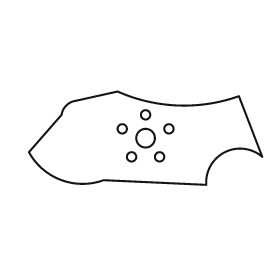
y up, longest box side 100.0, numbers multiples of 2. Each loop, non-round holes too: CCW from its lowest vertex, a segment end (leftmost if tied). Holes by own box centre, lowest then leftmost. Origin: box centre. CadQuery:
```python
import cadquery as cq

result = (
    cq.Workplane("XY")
    .moveTo(26.0, -20.0)
    .threePointArc((34.0, -6.0), (50.0, -8.0))
    .lineTo(40.0, 18.0)
    .threePointArc((14.0, 14.0), (-12.0, 20.0))
    .lineTo(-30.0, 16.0)
    .threePointArc((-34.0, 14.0), (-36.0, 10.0))
    .lineTo(-50.0, -6.0)
    .threePointArc((-36.0, -18.0), (-18.0, -18.0))
    .close()
    .moveTo(-6.0, -8.0)
    .circle(2.0)
    .moveTo(6.0, -8.0)
    .circle(2.0)
    .moveTo(0.0, 0.0)
    .circle(4.0)
    .moveTo(-10.0, 4.0)
    .circle(2.0)
    .moveTo(10.0, 4.0)
    .circle(2.0)
    .moveTo(0.0, 10.0)
    .circle(2.0)
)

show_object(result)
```